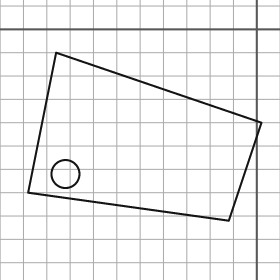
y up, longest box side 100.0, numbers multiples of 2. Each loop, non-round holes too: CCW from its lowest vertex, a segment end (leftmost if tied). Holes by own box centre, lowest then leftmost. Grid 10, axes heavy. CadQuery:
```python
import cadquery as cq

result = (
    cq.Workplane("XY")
    .moveTo(-12.0, -82.0)
    .lineTo(2.0, -40.0)
    .lineTo(-86.0, -10.0)
    .lineTo(-98.0, -70.0)
    .close()
    .moveTo(-82.0, -62.0)
    .circle(6.0)
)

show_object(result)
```